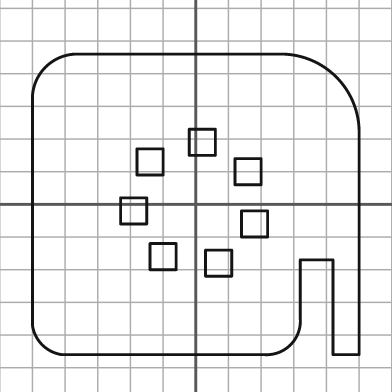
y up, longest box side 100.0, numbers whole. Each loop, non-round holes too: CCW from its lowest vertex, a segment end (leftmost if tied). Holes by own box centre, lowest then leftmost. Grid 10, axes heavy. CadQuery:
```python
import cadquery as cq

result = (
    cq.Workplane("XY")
    .moveTo(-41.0, -46.0)
    .lineTo(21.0, -46.0)
    .threePointArc((29.0, -43.0), (32.0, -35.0))
    .lineTo(32.0, -17.0)
    .lineTo(42.0, -17.0)
    .lineTo(42.0, -46.0)
    .lineTo(50.0, -46.0)
    .lineTo(50.0, 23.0)
    .threePointArc((43.0, 39.0), (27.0, 46.0))
    .lineTo(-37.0, 46.0)
    .threePointArc((-46.0, 42.0), (-50.0, 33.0))
    .lineTo(-50.0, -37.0)
    .threePointArc((-47.0, -43.0), (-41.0, -46.0))
    .close()
    .moveTo(3.0, -22.0)
    .lineTo(11.0, -22.0)
    .lineTo(11.0, -14.0)
    .lineTo(3.0, -14.0)
    .close()
    .moveTo(-14.0, -20.0)
    .lineTo(-6.0, -20.0)
    .lineTo(-6.0, -12.0)
    .lineTo(-14.0, -12.0)
    .close()
    .moveTo(14.0, -10.0)
    .lineTo(22.0, -10.0)
    .lineTo(22.0, -2.0)
    .lineTo(14.0, -2.0)
    .close()
    .moveTo(-23.0, -6.0)
    .lineTo(-15.0, -6.0)
    .lineTo(-15.0, 2.0)
    .lineTo(-23.0, 2.0)
    .close()
    .moveTo(12.0, 6.0)
    .lineTo(20.0, 6.0)
    .lineTo(20.0, 14.0)
    .lineTo(12.0, 14.0)
    .close()
    .moveTo(-18.0, 9.0)
    .lineTo(-10.0, 9.0)
    .lineTo(-10.0, 17.0)
    .lineTo(-18.0, 17.0)
    .close()
    .moveTo(-2.0, 15.0)
    .lineTo(6.0, 15.0)
    .lineTo(6.0, 23.0)
    .lineTo(-2.0, 23.0)
    .close()
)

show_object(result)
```